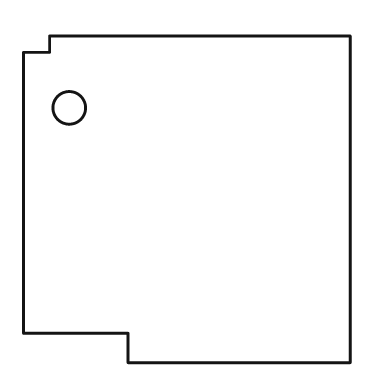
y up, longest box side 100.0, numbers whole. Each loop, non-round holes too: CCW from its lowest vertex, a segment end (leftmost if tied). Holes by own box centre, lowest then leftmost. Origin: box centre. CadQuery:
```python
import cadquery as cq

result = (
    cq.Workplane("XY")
    .moveTo(-18.0, -50.0)
    .lineTo(50.0, -50.0)
    .lineTo(50.0, 50.0)
    .lineTo(-42.0, 50.0)
    .lineTo(-42.0, 45.0)
    .lineTo(-50.0, 45.0)
    .lineTo(-50.0, -41.0)
    .lineTo(-18.0, -41.0)
    .close()
    .moveTo(-36.0, 28.0)
    .circle(5.0)
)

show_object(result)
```